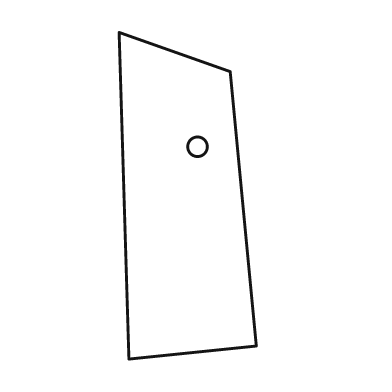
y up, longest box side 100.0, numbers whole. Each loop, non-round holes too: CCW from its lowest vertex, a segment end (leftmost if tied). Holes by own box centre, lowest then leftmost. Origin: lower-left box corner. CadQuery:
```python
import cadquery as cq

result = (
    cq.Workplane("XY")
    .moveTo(3.0, 0.0)
    .lineTo(42.0, 4.0)
    .lineTo(34.0, 88.0)
    .lineTo(0.0, 100.0)
    .close()
    .moveTo(24.0, 65.0)
    .circle(3.0)
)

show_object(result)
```